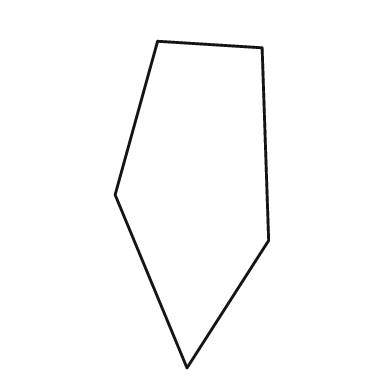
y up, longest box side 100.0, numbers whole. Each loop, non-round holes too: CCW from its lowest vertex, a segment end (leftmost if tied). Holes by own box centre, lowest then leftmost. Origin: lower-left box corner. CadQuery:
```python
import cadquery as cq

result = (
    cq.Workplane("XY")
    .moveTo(22.0, 0.0)
    .lineTo(47.0, 39.0)
    .lineTo(45.0, 98.0)
    .lineTo(13.0, 100.0)
    .lineTo(0.0, 53.0)
    .close()
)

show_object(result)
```